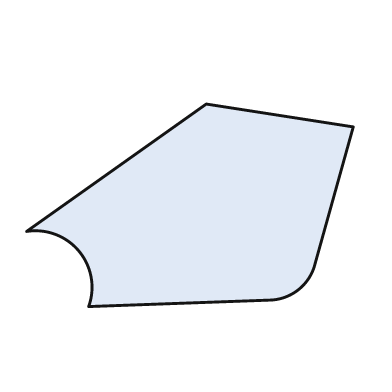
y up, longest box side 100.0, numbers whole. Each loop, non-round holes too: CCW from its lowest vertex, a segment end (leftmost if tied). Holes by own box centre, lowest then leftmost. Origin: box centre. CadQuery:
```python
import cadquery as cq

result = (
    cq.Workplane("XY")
    .moveTo(-31.0, -31.0)
    .lineTo(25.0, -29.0)
    .threePointArc((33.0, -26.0), (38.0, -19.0))
    .lineTo(50.0, 24.0)
    .lineTo(5.0, 31.0)
    .lineTo(-50.0, -8.0)
    .threePointArc((-34.0, -14.0), (-31.0, -31.0))
    .close()
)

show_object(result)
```